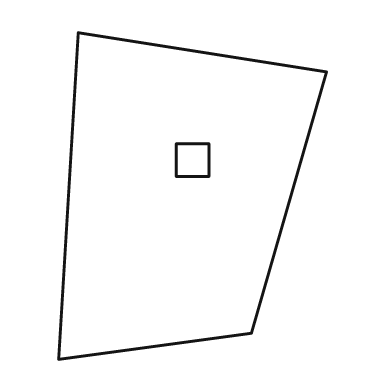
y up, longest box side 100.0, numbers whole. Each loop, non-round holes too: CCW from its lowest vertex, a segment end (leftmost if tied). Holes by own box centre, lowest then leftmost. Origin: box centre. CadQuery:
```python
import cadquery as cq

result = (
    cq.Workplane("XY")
    .moveTo(-41.0, -50.0)
    .lineTo(18.0, -42.0)
    .lineTo(41.0, 38.0)
    .lineTo(-35.0, 50.0)
    .close()
    .moveTo(-5.0, 6.0)
    .lineTo(5.0, 6.0)
    .lineTo(5.0, 16.0)
    .lineTo(-5.0, 16.0)
    .close()
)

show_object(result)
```